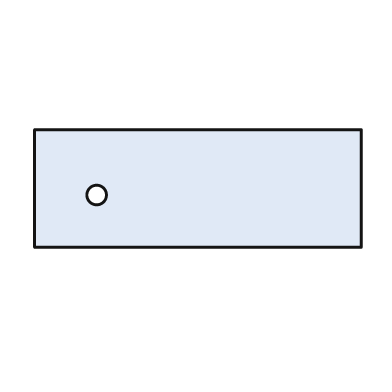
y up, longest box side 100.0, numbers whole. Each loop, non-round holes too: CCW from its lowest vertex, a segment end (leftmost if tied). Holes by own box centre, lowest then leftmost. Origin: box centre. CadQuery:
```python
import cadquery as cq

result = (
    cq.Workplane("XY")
    .moveTo(-50.0, -18.0)
    .lineTo(50.0, -18.0)
    .lineTo(50.0, 18.0)
    .lineTo(-50.0, 18.0)
    .close()
    .moveTo(-31.0, -2.0)
    .circle(3.0)
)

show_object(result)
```